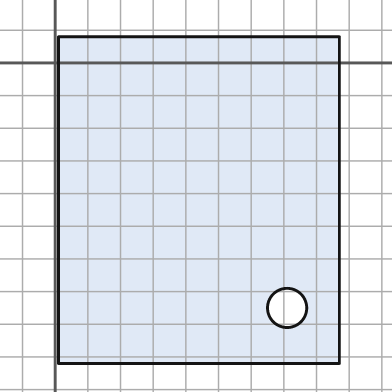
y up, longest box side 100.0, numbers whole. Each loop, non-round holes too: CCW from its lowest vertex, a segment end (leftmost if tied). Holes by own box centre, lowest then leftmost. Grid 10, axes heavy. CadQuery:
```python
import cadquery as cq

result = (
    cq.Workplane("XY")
    .moveTo(1.0, -92.0)
    .lineTo(87.0, -92.0)
    .lineTo(87.0, 8.0)
    .lineTo(1.0, 8.0)
    .close()
    .moveTo(71.0, -75.0)
    .circle(6.0)
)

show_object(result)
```